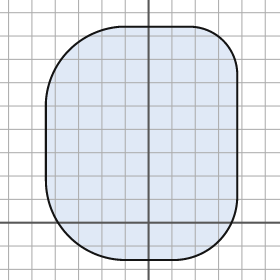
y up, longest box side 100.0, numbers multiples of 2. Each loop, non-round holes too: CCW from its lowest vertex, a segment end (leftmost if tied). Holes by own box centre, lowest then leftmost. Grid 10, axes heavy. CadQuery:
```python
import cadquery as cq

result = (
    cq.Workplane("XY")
    .moveTo(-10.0, -16.0)
    .lineTo(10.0, -16.0)
    .threePointArc((30.0, -8.0), (38.0, 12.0))
    .lineTo(38.0, 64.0)
    .threePointArc((32.0, 78.0), (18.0, 84.0))
    .lineTo(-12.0, 84.0)
    .threePointArc((-34.0, 74.0), (-44.0, 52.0))
    .lineTo(-44.0, 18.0)
    .threePointArc((-34.0, -6.0), (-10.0, -16.0))
    .close()
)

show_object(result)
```